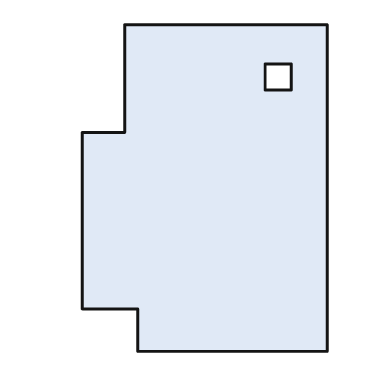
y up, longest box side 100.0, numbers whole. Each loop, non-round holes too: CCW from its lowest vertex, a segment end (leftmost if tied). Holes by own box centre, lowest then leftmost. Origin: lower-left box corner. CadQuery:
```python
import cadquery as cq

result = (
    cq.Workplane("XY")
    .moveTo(17.0, 0.0)
    .lineTo(75.0, 0.0)
    .lineTo(75.0, 100.0)
    .lineTo(13.0, 100.0)
    .lineTo(13.0, 67.0)
    .lineTo(0.0, 67.0)
    .lineTo(0.0, 13.0)
    .lineTo(17.0, 13.0)
    .close()
    .moveTo(56.0, 80.0)
    .lineTo(64.0, 80.0)
    .lineTo(64.0, 88.0)
    .lineTo(56.0, 88.0)
    .close()
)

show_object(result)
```